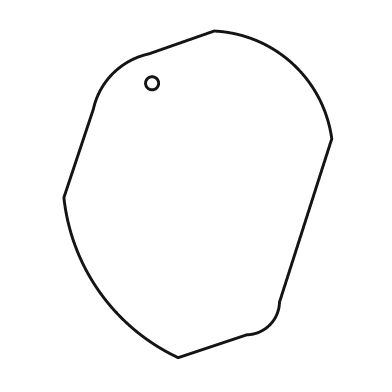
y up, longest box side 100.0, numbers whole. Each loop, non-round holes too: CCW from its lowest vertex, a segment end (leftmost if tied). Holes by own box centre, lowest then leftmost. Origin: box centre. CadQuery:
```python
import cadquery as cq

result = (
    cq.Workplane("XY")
    .moveTo(-6.0, -50.0)
    .lineTo(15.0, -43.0)
    .threePointArc((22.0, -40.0), (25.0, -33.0))
    .lineTo(41.0, 17.0)
    .threePointArc((29.0, 40.0), (5.0, 50.0))
    .lineTo(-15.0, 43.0)
    .threePointArc((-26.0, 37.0), (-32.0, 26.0))
    .lineTo(-41.0, -1.0)
    .threePointArc((-30.0, -30.0), (-6.0, -50.0))
    .close()
    .moveTo(-14.0, 34.0)
    .circle(2.0)
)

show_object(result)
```